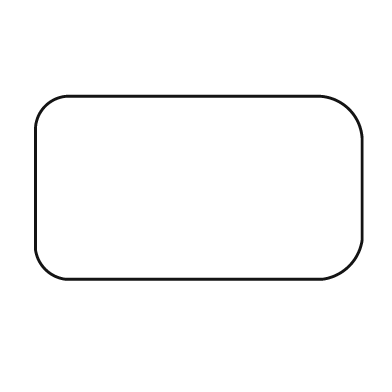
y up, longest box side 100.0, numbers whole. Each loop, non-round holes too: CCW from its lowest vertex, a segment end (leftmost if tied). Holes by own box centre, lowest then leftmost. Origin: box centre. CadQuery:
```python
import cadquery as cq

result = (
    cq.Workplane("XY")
    .moveTo(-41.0, -28.0)
    .lineTo(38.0, -28.0)
    .threePointArc((46.0, -24.0), (50.0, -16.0))
    .lineTo(50.0, 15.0)
    .threePointArc((46.0, 24.0), (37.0, 28.0))
    .lineTo(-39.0, 28.0)
    .threePointArc((-47.0, 25.0), (-50.0, 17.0))
    .lineTo(-50.0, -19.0)
    .threePointArc((-47.0, -25.0), (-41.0, -28.0))
    .close()
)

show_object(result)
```